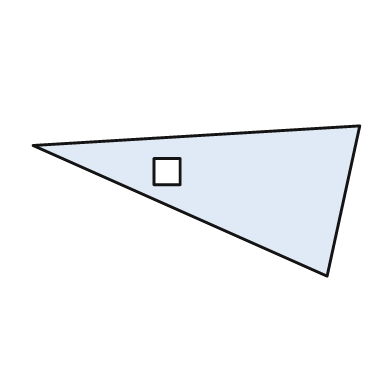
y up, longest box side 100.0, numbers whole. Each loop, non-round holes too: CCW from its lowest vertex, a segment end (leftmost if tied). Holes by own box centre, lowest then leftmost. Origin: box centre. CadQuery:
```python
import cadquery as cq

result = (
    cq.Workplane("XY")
    .moveTo(40.0, -23.0)
    .lineTo(50.0, 23.0)
    .lineTo(-50.0, 17.0)
    .close()
    .moveTo(-13.0, 5.0)
    .lineTo(-5.0, 5.0)
    .lineTo(-5.0, 13.0)
    .lineTo(-13.0, 13.0)
    .close()
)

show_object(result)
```